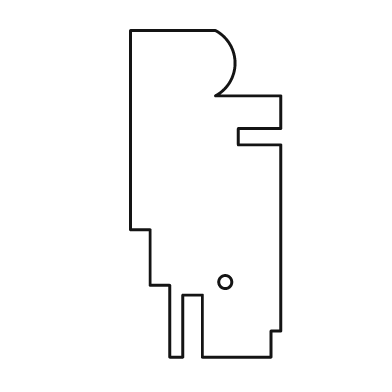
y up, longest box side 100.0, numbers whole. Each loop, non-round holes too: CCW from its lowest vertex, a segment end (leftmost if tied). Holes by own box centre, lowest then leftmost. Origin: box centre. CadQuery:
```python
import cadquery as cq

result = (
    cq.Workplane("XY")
    .moveTo(-11.0, -50.0)
    .lineTo(-7.0, -50.0)
    .lineTo(-7.0, -31.0)
    .lineTo(-1.0, -31.0)
    .lineTo(-1.0, -50.0)
    .lineTo(20.0, -50.0)
    .lineTo(20.0, -42.0)
    .lineTo(23.0, -42.0)
    .lineTo(23.0, 15.0)
    .lineTo(10.0, 15.0)
    .lineTo(10.0, 20.0)
    .lineTo(23.0, 20.0)
    .lineTo(23.0, 30.0)
    .lineTo(3.0, 30.0)
    .threePointArc((9.0, 40.0), (3.0, 50.0))
    .lineTo(-23.0, 50.0)
    .lineTo(-23.0, -11.0)
    .lineTo(-17.0, -11.0)
    .lineTo(-17.0, -28.0)
    .lineTo(-11.0, -28.0)
    .close()
    .moveTo(6.0, -27.0)
    .circle(2.0)
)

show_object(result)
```